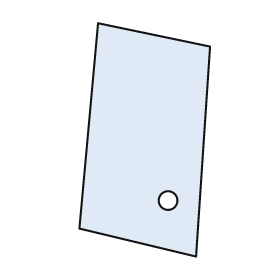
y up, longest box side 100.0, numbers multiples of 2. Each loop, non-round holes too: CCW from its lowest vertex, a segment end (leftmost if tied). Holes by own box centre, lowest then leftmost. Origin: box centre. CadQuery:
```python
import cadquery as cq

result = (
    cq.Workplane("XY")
    .moveTo(22.0, -50.0)
    .lineTo(28.0, 40.0)
    .lineTo(-20.0, 50.0)
    .lineTo(-28.0, -38.0)
    .close()
    .moveTo(10.0, -26.0)
    .circle(4.0)
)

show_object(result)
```